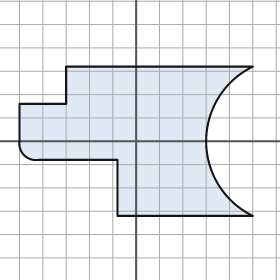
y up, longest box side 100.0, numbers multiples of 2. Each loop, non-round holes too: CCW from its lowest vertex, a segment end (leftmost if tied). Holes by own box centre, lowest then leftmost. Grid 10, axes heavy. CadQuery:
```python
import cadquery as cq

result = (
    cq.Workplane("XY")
    .moveTo(-8.0, -32.0)
    .lineTo(50.0, -32.0)
    .threePointArc((30.0, 0.0), (50.0, 32.0))
    .lineTo(-30.0, 32.0)
    .lineTo(-30.0, 16.0)
    .lineTo(-50.0, 16.0)
    .lineTo(-50.0, 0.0)
    .threePointArc((-48.0, -6.0), (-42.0, -8.0))
    .lineTo(-8.0, -8.0)
    .close()
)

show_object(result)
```